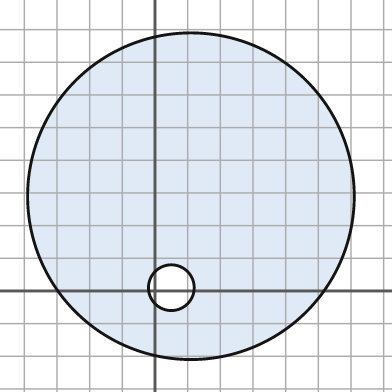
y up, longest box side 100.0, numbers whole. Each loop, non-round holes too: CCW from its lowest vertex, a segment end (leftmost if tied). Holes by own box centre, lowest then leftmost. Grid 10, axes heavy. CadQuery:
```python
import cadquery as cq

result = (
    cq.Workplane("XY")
    .moveTo(11.0, 29.0)
    .circle(50.0)
    .moveTo(5.0, 1.0)
    .circle(7.0)
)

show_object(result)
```